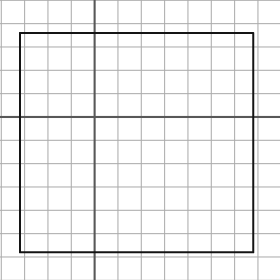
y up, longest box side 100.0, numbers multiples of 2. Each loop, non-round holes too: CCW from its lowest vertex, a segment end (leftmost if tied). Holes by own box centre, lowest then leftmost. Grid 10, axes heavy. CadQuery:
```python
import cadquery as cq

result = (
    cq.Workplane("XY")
    .moveTo(-32.0, -58.0)
    .lineTo(68.0, -58.0)
    .lineTo(68.0, 36.0)
    .lineTo(-32.0, 36.0)
    .close()
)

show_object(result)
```